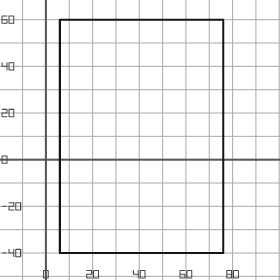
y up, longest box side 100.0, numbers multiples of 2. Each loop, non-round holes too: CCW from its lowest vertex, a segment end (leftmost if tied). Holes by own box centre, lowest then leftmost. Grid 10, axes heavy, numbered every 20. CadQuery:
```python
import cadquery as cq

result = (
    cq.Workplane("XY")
    .moveTo(6.0, -40.0)
    .lineTo(76.0, -40.0)
    .lineTo(76.0, 60.0)
    .lineTo(6.0, 60.0)
    .close()
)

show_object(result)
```